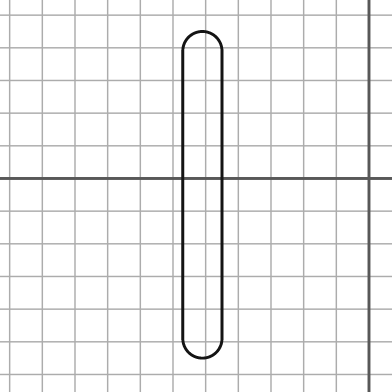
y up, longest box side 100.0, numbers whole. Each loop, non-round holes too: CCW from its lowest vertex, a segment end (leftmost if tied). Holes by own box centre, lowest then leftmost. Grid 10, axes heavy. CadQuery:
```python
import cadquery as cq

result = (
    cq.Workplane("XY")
    .moveTo(-57.0, -49.0)
    .threePointArc((-51.0, -55.0), (-45.0, -49.0))
    .lineTo(-45.0, 39.0)
    .threePointArc((-51.0, 45.0), (-57.0, 39.0))
    .close()
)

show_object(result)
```